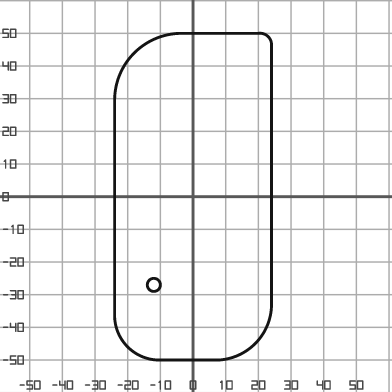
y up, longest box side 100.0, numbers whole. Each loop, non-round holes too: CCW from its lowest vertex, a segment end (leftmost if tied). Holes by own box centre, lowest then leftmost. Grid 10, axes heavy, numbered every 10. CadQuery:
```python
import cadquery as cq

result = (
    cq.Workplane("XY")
    .moveTo(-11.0, -50.0)
    .lineTo(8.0, -50.0)
    .threePointArc((19.0, -45.0), (24.0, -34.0))
    .lineTo(24.0, 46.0)
    .threePointArc((23.0, 49.0), (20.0, 50.0))
    .lineTo(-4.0, 50.0)
    .threePointArc((-18.0, 44.0), (-24.0, 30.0))
    .lineTo(-24.0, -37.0)
    .threePointArc((-20.0, -46.0), (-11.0, -50.0))
    .close()
    .moveTo(-12.0, -27.0)
    .circle(2.0)
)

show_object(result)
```